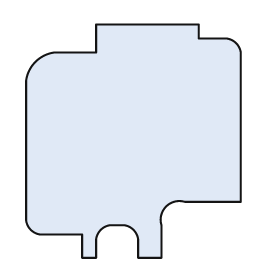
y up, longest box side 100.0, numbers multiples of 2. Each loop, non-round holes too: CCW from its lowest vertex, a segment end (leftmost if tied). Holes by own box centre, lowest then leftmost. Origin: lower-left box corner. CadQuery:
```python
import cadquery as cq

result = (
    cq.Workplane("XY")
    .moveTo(24.0, 0.0)
    .lineTo(30.0, 0.0)
    .lineTo(30.0, 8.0)
    .threePointArc((32.0, 12.0), (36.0, 14.0))
    .lineTo(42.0, 14.0)
    .threePointArc((46.0, 12.0), (48.0, 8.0))
    .lineTo(48.0, 0.0)
    .lineTo(58.0, 0.0)
    .lineTo(58.0, 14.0)
    .threePointArc((60.0, 22.0), (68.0, 24.0))
    .lineTo(92.0, 24.0)
    .lineTo(92.0, 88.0)
    .threePointArc((90.0, 92.0), (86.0, 94.0))
    .lineTo(74.0, 94.0)
    .lineTo(74.0, 100.0)
    .lineTo(30.0, 100.0)
    .lineTo(30.0, 88.0)
    .lineTo(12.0, 88.0)
    .threePointArc((4.0, 84.0), (0.0, 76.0))
    .lineTo(0.0, 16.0)
    .threePointArc((2.0, 12.0), (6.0, 10.0))
    .lineTo(24.0, 10.0)
    .close()
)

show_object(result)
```